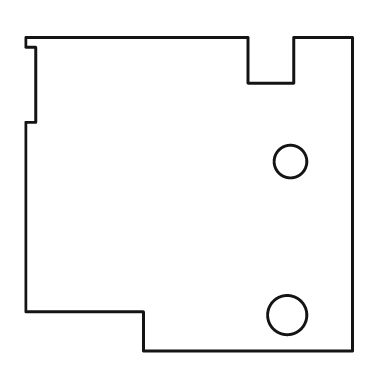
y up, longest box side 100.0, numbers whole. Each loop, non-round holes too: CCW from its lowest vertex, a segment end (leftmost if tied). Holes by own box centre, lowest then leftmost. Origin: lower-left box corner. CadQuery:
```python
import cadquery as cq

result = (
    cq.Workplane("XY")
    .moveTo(36.0, 0.0)
    .lineTo(100.0, 0.0)
    .lineTo(100.0, 96.0)
    .lineTo(82.0, 96.0)
    .lineTo(82.0, 82.0)
    .lineTo(68.0, 82.0)
    .lineTo(68.0, 96.0)
    .lineTo(0.0, 96.0)
    .lineTo(0.0, 93.0)
    .lineTo(3.0, 93.0)
    .lineTo(3.0, 70.0)
    .lineTo(0.0, 70.0)
    .lineTo(0.0, 12.0)
    .lineTo(36.0, 12.0)
    .close()
    .moveTo(80.0, 11.0)
    .circle(6.0)
    .moveTo(81.0, 58.0)
    .circle(5.0)
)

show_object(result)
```